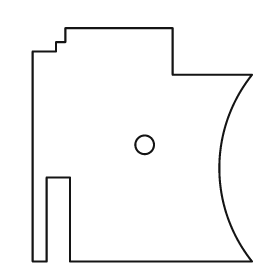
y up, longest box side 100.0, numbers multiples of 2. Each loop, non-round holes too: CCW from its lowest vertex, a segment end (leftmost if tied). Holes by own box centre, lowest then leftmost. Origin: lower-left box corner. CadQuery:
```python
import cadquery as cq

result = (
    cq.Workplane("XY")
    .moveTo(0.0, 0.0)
    .lineTo(6.0, 0.0)
    .lineTo(6.0, 36.0)
    .lineTo(16.0, 36.0)
    .lineTo(16.0, 0.0)
    .lineTo(94.0, 0.0)
    .threePointArc((80.0, 40.0), (94.0, 80.0))
    .lineTo(60.0, 80.0)
    .lineTo(60.0, 100.0)
    .lineTo(14.0, 100.0)
    .lineTo(14.0, 94.0)
    .lineTo(10.0, 94.0)
    .lineTo(10.0, 90.0)
    .lineTo(0.0, 90.0)
    .close()
    .moveTo(48.0, 50.0)
    .circle(4.0)
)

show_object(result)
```